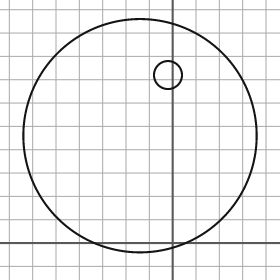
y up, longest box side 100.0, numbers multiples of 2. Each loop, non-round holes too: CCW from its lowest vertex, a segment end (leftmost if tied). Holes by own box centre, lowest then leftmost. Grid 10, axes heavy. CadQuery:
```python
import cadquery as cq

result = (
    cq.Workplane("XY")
    .moveTo(-14.0, 46.0)
    .circle(50.0)
    .moveTo(-2.0, 72.0)
    .circle(6.0)
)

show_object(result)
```